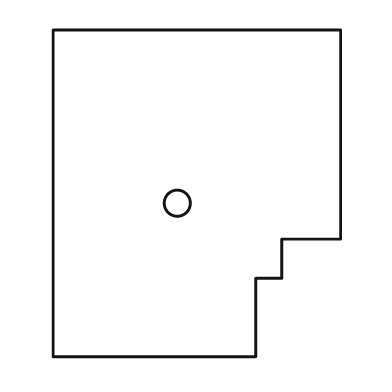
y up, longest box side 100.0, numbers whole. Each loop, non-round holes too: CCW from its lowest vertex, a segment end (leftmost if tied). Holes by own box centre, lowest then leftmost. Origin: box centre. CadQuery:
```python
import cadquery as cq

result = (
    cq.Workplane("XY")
    .moveTo(-44.0, -50.0)
    .lineTo(18.0, -50.0)
    .lineTo(18.0, -26.0)
    .lineTo(26.0, -26.0)
    .lineTo(26.0, -14.0)
    .lineTo(44.0, -14.0)
    .lineTo(44.0, 50.0)
    .lineTo(-44.0, 50.0)
    .close()
    .moveTo(-6.0, -3.0)
    .circle(4.0)
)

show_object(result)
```